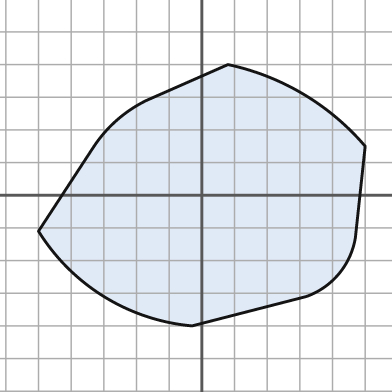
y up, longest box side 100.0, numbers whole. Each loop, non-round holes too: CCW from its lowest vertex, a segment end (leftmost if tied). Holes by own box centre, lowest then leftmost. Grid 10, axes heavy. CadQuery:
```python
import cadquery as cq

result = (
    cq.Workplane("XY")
    .moveTo(-3.0, -40.0)
    .lineTo(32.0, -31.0)
    .threePointArc((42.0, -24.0), (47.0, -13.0))
    .lineTo(50.0, 15.0)
    .threePointArc((31.0, 31.0), (8.0, 40.0))
    .lineTo(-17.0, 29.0)
    .threePointArc((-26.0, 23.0), (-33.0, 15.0))
    .lineTo(-50.0, -11.0)
    .threePointArc((-30.0, -31.0), (-3.0, -40.0))
    .close()
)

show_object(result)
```